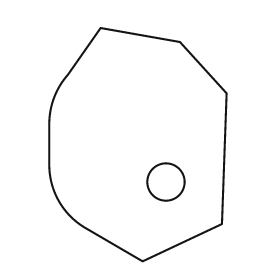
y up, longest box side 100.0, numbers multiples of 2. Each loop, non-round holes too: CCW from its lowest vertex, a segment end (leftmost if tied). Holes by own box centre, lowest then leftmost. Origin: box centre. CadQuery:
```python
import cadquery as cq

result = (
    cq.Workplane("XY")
    .moveTo(2.0, -50.0)
    .lineTo(36.0, -34.0)
    .lineTo(38.0, 22.0)
    .lineTo(18.0, 44.0)
    .lineTo(-16.0, 50.0)
    .lineTo(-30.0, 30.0)
    .threePointArc((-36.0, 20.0), (-38.0, 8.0))
    .lineTo(-38.0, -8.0)
    .threePointArc((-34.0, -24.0), (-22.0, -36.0))
    .close()
    .moveTo(12.0, -16.0)
    .circle(8.0)
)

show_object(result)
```